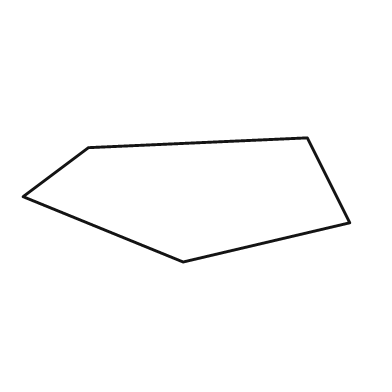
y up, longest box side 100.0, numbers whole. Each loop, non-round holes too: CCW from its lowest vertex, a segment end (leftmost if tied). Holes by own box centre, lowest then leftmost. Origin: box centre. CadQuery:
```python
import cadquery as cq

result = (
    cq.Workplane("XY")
    .moveTo(-1.0, -19.0)
    .lineTo(50.0, -7.0)
    .lineTo(37.0, 19.0)
    .lineTo(-30.0, 16.0)
    .lineTo(-50.0, 1.0)
    .close()
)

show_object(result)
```